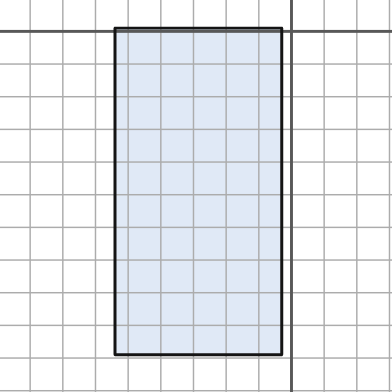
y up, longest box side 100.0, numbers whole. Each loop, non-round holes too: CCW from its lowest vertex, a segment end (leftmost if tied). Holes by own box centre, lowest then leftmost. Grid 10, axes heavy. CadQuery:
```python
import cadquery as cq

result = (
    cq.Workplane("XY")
    .moveTo(-54.0, -99.0)
    .lineTo(-3.0, -99.0)
    .lineTo(-3.0, 1.0)
    .lineTo(-54.0, 1.0)
    .close()
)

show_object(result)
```